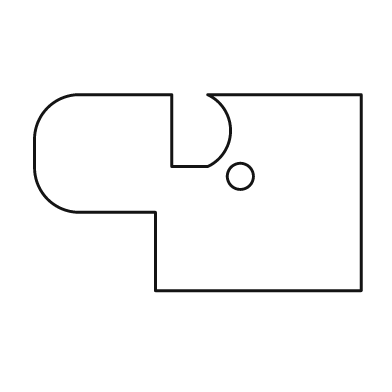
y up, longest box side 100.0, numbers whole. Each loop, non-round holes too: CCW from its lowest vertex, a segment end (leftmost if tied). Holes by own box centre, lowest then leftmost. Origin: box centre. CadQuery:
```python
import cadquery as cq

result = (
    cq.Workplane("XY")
    .moveTo(-13.0, -30.0)
    .lineTo(50.0, -30.0)
    .lineTo(50.0, 30.0)
    .lineTo(3.0, 30.0)
    .threePointArc((10.0, 19.0), (3.0, 8.0))
    .lineTo(-8.0, 8.0)
    .lineTo(-8.0, 30.0)
    .lineTo(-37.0, 30.0)
    .threePointArc((-46.0, 26.0), (-50.0, 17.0))
    .lineTo(-50.0, 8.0)
    .threePointArc((-46.0, -2.0), (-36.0, -6.0))
    .lineTo(-13.0, -6.0)
    .close()
    .moveTo(13.0, 5.0)
    .circle(4.0)
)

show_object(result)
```